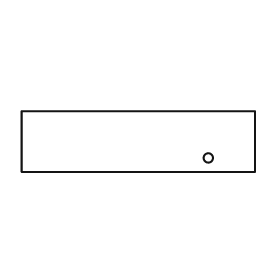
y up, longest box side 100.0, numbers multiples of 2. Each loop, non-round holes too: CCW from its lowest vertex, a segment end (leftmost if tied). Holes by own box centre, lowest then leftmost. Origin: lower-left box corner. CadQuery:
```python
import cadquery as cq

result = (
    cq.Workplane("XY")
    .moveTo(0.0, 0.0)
    .lineTo(100.0, 0.0)
    .lineTo(100.0, 26.0)
    .lineTo(0.0, 26.0)
    .close()
    .moveTo(80.0, 6.0)
    .circle(2.0)
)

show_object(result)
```